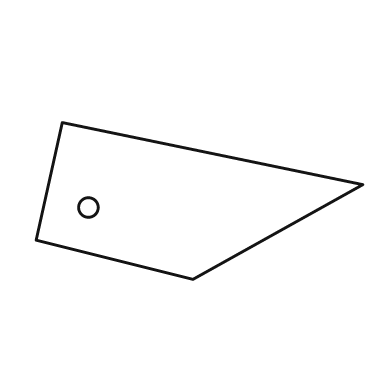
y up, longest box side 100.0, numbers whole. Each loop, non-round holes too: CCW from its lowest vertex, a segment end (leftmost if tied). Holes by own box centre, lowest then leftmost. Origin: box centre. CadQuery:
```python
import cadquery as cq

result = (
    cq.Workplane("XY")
    .moveTo(-2.0, -24.0)
    .lineTo(50.0, 5.0)
    .lineTo(-42.0, 24.0)
    .lineTo(-50.0, -12.0)
    .close()
    .moveTo(-34.0, -2.0)
    .circle(3.0)
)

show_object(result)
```